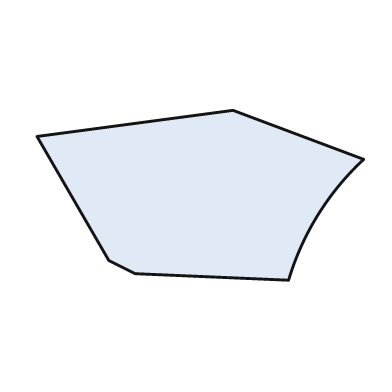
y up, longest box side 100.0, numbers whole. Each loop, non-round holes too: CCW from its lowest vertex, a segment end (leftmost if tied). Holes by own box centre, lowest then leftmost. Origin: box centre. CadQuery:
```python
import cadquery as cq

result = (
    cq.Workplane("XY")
    .moveTo(27.0, -26.0)
    .threePointArc((36.0, -6.0), (50.0, 11.0))
    .lineTo(10.0, 26.0)
    .lineTo(-50.0, 18.0)
    .lineTo(-28.0, -20.0)
    .lineTo(-20.0, -24.0)
    .close()
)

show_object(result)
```